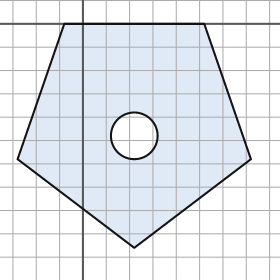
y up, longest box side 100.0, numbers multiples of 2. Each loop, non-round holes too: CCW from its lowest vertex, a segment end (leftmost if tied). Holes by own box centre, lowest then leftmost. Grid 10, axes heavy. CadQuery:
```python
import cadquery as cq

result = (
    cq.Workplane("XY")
    .moveTo(22.0, -96.0)
    .lineTo(72.0, -58.0)
    .lineTo(52.0, 0.0)
    .lineTo(-8.0, 0.0)
    .lineTo(-28.0, -58.0)
    .close()
    .moveTo(22.0, -48.0)
    .circle(10.0)
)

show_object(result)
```